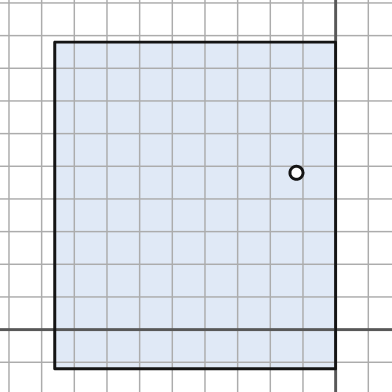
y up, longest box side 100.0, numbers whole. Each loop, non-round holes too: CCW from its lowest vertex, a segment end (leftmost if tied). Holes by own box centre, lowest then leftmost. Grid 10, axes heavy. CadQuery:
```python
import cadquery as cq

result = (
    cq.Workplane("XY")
    .moveTo(-86.0, -12.0)
    .lineTo(0.0, -12.0)
    .lineTo(0.0, 88.0)
    .lineTo(-86.0, 88.0)
    .close()
    .moveTo(-12.0, 48.0)
    .circle(2.0)
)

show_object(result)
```